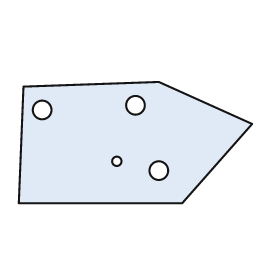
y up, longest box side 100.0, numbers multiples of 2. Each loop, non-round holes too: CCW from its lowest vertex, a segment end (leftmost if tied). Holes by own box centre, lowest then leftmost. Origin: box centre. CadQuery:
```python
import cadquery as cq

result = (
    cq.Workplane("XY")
    .moveTo(-50.0, -26.0)
    .lineTo(20.0, -26.0)
    .lineTo(50.0, 8.0)
    .lineTo(10.0, 26.0)
    .lineTo(-48.0, 24.0)
    .close()
    .moveTo(10.0, -12.0)
    .circle(4.0)
    .moveTo(-8.0, -8.0)
    .circle(2.0)
    .moveTo(-40.0, 14.0)
    .circle(4.0)
    .moveTo(0.0, 16.0)
    .circle(4.0)
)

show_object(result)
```